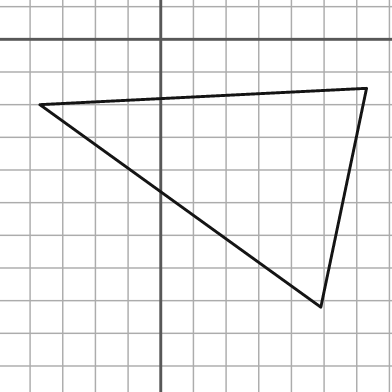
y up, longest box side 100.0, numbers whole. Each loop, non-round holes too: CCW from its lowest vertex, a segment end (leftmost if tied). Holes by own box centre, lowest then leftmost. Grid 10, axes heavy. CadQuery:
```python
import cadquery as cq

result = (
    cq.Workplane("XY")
    .moveTo(49.0, -82.0)
    .lineTo(63.0, -15.0)
    .lineTo(-37.0, -20.0)
    .close()
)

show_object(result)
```